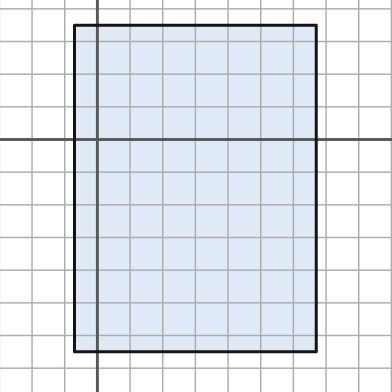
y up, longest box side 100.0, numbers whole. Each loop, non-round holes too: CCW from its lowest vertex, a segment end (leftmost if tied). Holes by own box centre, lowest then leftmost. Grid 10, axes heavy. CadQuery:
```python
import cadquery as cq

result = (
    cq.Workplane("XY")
    .moveTo(-7.0, -65.0)
    .lineTo(67.0, -65.0)
    .lineTo(67.0, 35.0)
    .lineTo(-7.0, 35.0)
    .close()
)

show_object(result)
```